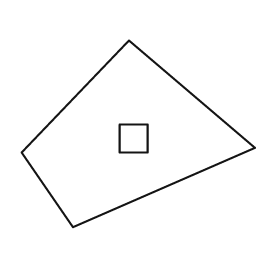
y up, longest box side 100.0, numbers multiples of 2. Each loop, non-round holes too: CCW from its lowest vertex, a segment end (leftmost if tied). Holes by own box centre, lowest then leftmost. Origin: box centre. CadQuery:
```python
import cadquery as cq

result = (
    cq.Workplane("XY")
    .moveTo(-28.0, -40.0)
    .lineTo(50.0, -6.0)
    .lineTo(-4.0, 40.0)
    .lineTo(-50.0, -8.0)
    .close()
    .moveTo(-8.0, -8.0)
    .lineTo(4.0, -8.0)
    .lineTo(4.0, 4.0)
    .lineTo(-8.0, 4.0)
    .close()
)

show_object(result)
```